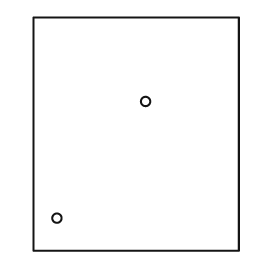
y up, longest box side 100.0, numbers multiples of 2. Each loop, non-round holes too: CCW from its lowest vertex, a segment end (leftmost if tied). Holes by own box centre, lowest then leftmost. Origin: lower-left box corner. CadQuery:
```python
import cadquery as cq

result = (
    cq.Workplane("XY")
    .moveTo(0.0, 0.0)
    .lineTo(88.0, 0.0)
    .lineTo(88.0, 100.0)
    .lineTo(0.0, 100.0)
    .close()
    .moveTo(10.0, 14.0)
    .circle(2.0)
    .moveTo(48.0, 64.0)
    .circle(2.0)
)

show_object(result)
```